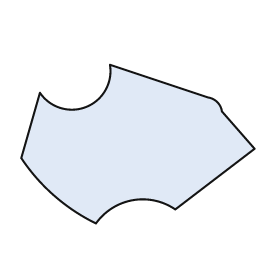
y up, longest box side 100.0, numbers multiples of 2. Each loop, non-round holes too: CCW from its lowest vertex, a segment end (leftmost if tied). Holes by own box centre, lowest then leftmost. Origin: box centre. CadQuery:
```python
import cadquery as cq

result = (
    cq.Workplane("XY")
    .moveTo(-18.0, -34.0)
    .threePointArc((-2.0, -24.0), (16.0, -28.0))
    .lineTo(50.0, -2.0)
    .lineTo(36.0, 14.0)
    .threePointArc((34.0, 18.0), (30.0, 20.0))
    .lineTo(-12.0, 34.0)
    .threePointArc((-22.0, 16.0), (-42.0, 22.0))
    .lineTo(-50.0, -6.0)
    .threePointArc((-36.0, -22.0), (-18.0, -34.0))
    .close()
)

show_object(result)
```